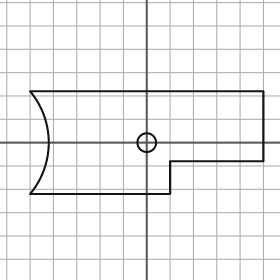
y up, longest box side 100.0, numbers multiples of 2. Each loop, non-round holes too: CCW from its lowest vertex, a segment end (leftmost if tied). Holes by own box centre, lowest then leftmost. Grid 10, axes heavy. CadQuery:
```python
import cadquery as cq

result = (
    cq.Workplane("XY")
    .moveTo(-50.0, -22.0)
    .lineTo(10.0, -22.0)
    .lineTo(10.0, -8.0)
    .lineTo(50.0, -8.0)
    .lineTo(50.0, 22.0)
    .lineTo(-50.0, 22.0)
    .threePointArc((-42.0, 0.0), (-50.0, -22.0))
    .close()
    .moveTo(0.0, 0.0)
    .circle(4.0)
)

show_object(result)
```